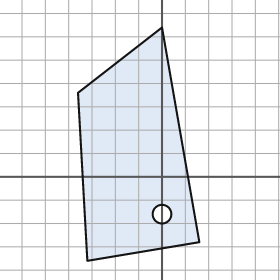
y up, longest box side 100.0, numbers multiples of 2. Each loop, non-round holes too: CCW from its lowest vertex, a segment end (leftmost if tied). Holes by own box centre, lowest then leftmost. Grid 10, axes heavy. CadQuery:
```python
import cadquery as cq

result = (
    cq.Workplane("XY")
    .moveTo(-32.0, -36.0)
    .lineTo(16.0, -28.0)
    .lineTo(0.0, 64.0)
    .lineTo(-36.0, 36.0)
    .close()
    .moveTo(0.0, -16.0)
    .circle(4.0)
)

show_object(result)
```